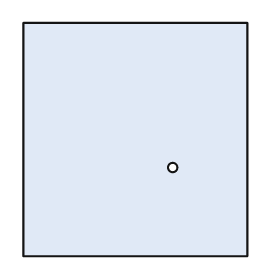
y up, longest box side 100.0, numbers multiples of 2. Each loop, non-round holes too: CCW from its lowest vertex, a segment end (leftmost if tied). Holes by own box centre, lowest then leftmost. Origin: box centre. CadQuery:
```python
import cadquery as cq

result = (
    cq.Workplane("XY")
    .moveTo(-48.0, -50.0)
    .lineTo(48.0, -50.0)
    .lineTo(48.0, 50.0)
    .lineTo(-48.0, 50.0)
    .close()
    .moveTo(16.0, -12.0)
    .circle(2.0)
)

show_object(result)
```